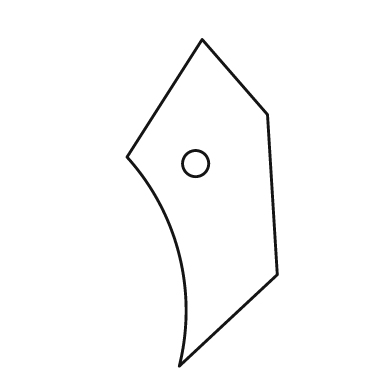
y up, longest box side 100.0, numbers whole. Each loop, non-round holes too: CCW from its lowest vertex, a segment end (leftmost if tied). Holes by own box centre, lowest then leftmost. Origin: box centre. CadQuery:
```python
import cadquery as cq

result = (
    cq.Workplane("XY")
    .moveTo(-7.0, -50.0)
    .lineTo(23.0, -22.0)
    .lineTo(20.0, 27.0)
    .lineTo(0.0, 50.0)
    .lineTo(-23.0, 14.0)
    .threePointArc((-7.0, -16.0), (-7.0, -50.0))
    .close()
    .moveTo(-2.0, 12.0)
    .circle(4.0)
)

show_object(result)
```